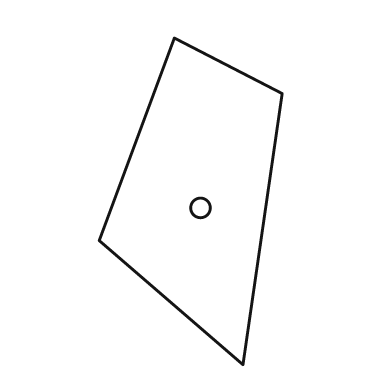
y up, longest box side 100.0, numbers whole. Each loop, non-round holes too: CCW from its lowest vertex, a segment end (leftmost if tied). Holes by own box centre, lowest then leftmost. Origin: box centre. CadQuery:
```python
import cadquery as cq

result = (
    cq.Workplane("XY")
    .moveTo(16.0, -50.0)
    .lineTo(28.0, 33.0)
    .lineTo(-5.0, 50.0)
    .lineTo(-28.0, -12.0)
    .close()
    .moveTo(3.0, -2.0)
    .circle(3.0)
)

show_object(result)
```